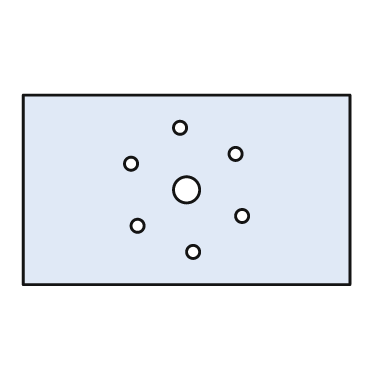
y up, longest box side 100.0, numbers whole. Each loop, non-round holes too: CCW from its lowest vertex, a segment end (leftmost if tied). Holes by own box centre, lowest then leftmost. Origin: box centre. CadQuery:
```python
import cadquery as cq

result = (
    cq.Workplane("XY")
    .moveTo(-50.0, -29.0)
    .lineTo(50.0, -29.0)
    .lineTo(50.0, 29.0)
    .lineTo(-50.0, 29.0)
    .close()
    .moveTo(2.0, -19.0)
    .circle(2.0)
    .moveTo(-15.0, -11.0)
    .circle(2.0)
    .moveTo(17.0, -8.0)
    .circle(2.0)
    .moveTo(0.0, 0.0)
    .circle(4.0)
    .moveTo(-17.0, 8.0)
    .circle(2.0)
    .moveTo(15.0, 11.0)
    .circle(2.0)
    .moveTo(-2.0, 19.0)
    .circle(2.0)
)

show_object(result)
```